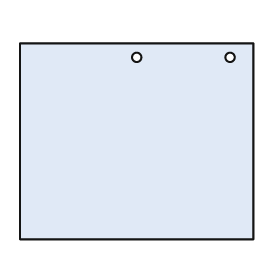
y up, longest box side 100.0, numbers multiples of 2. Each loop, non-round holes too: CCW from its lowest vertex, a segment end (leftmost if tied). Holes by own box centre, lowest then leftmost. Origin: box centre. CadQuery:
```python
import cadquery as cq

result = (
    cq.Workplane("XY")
    .moveTo(-50.0, -42.0)
    .lineTo(50.0, -42.0)
    .lineTo(50.0, 42.0)
    .lineTo(-50.0, 42.0)
    .close()
    .moveTo(0.0, 36.0)
    .circle(2.0)
    .moveTo(40.0, 36.0)
    .circle(2.0)
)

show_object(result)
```